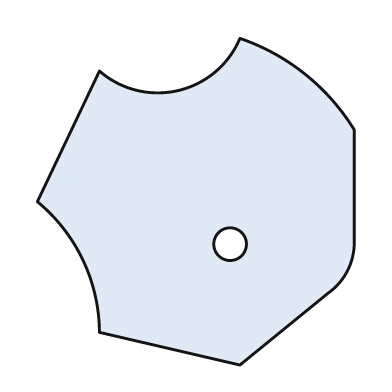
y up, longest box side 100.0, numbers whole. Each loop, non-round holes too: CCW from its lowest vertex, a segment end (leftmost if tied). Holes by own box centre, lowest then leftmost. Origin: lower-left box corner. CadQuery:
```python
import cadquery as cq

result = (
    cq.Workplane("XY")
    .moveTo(62.0, 0.0)
    .lineTo(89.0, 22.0)
    .threePointArc((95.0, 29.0), (97.0, 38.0))
    .lineTo(97.0, 72.0)
    .threePointArc((82.0, 89.0), (62.0, 100.0))
    .threePointArc((43.0, 84.0), (19.0, 90.0))
    .lineTo(0.0, 50.0)
    .threePointArc((14.0, 32.0), (19.0, 10.0))
    .close()
    .moveTo(59.0, 37.0)
    .circle(5.0)
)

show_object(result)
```